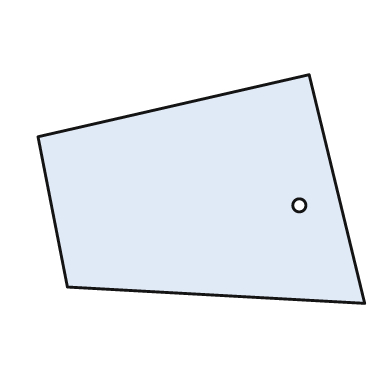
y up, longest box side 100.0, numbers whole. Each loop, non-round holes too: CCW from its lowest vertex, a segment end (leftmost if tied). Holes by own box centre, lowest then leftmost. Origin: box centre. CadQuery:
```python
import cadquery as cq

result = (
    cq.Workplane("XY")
    .moveTo(50.0, -35.0)
    .lineTo(33.0, 35.0)
    .lineTo(-50.0, 16.0)
    .lineTo(-41.0, -30.0)
    .close()
    .moveTo(30.0, -5.0)
    .circle(2.0)
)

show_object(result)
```